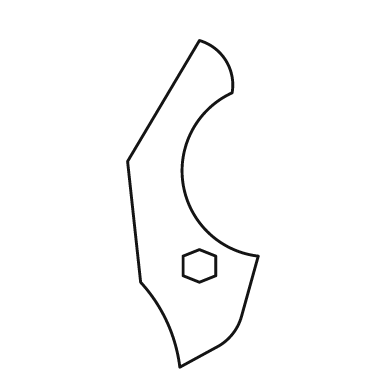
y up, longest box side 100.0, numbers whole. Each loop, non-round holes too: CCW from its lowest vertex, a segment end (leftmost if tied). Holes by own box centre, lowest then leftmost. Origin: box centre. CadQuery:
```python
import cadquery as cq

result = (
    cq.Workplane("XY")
    .moveTo(-4.0, -50.0)
    .lineTo(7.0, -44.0)
    .threePointArc((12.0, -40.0), (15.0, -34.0))
    .lineTo(20.0, -16.0)
    .threePointArc((-3.0, 6.0), (12.0, 34.0))
    .threePointArc((10.0, 44.0), (2.0, 50.0))
    .lineTo(-20.0, 13.0)
    .lineTo(-16.0, -24.0)
    .threePointArc((-8.0, -36.0), (-4.0, -50.0))
    .close()
    .moveTo(2.0, -24.0)
    .lineTo(7.0, -22.0)
    .lineTo(7.0, -16.0)
    .lineTo(2.0, -14.0)
    .lineTo(-3.0, -16.0)
    .lineTo(-3.0, -22.0)
    .close()
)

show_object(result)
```